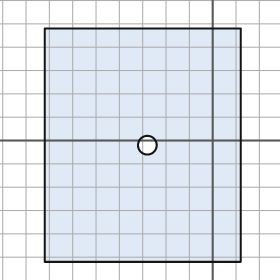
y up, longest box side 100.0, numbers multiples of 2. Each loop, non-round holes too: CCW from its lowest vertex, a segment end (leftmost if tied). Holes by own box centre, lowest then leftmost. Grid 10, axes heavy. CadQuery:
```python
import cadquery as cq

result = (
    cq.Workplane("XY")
    .moveTo(-72.0, -52.0)
    .lineTo(12.0, -52.0)
    .lineTo(12.0, 48.0)
    .lineTo(-72.0, 48.0)
    .close()
    .moveTo(-28.0, -2.0)
    .circle(4.0)
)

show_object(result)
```